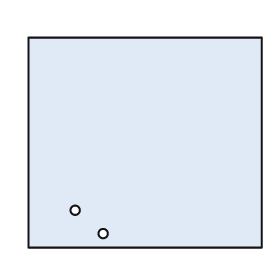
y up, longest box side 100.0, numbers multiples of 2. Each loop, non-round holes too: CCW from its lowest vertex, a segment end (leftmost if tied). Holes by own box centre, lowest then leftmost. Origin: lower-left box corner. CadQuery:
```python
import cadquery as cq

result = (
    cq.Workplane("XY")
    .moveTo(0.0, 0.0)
    .lineTo(100.0, 0.0)
    .lineTo(100.0, 90.0)
    .lineTo(0.0, 90.0)
    .close()
    .moveTo(32.0, 6.0)
    .circle(2.0)
    .moveTo(20.0, 16.0)
    .circle(2.0)
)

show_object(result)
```